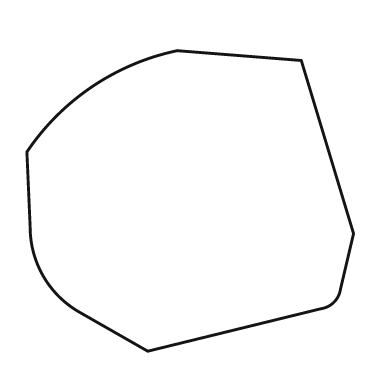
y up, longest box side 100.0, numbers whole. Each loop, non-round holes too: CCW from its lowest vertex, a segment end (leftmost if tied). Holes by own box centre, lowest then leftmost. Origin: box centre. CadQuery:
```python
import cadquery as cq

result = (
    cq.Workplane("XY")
    .moveTo(-13.0, -46.0)
    .lineTo(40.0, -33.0)
    .threePointArc((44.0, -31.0), (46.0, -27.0))
    .lineTo(50.0, -10.0)
    .lineTo(34.0, 43.0)
    .lineTo(-4.0, 46.0)
    .threePointArc((-30.0, 35.0), (-50.0, 15.0))
    .lineTo(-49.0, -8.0)
    .threePointArc((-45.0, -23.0), (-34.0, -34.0))
    .close()
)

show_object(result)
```